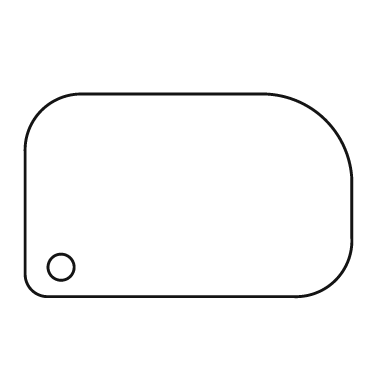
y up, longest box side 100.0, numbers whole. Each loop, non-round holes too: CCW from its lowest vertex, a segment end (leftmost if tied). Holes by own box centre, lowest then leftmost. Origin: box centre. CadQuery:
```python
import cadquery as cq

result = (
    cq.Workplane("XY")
    .moveTo(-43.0, -31.0)
    .lineTo(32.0, -31.0)
    .threePointArc((45.0, -26.0), (50.0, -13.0))
    .lineTo(50.0, 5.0)
    .threePointArc((42.0, 23.0), (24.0, 31.0))
    .lineTo(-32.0, 31.0)
    .threePointArc((-45.0, 26.0), (-50.0, 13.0))
    .lineTo(-50.0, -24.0)
    .threePointArc((-48.0, -29.0), (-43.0, -31.0))
    .close()
    .moveTo(-39.0, -22.0)
    .circle(4.0)
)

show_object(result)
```